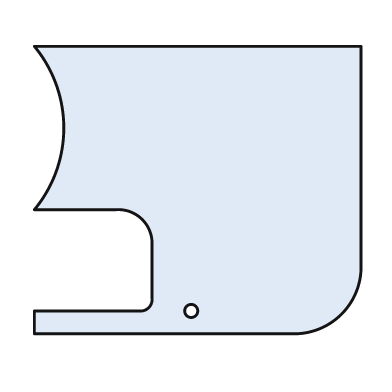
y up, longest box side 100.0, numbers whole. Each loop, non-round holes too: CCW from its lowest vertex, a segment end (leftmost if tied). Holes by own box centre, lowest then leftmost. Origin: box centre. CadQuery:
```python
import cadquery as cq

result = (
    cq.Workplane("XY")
    .moveTo(-50.0, -44.0)
    .lineTo(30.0, -44.0)
    .threePointArc((44.0, -38.0), (50.0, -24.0))
    .lineTo(50.0, 44.0)
    .lineTo(-50.0, 44.0)
    .threePointArc((-41.0, 19.0), (-50.0, -6.0))
    .lineTo(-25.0, -6.0)
    .threePointArc((-17.0, -9.0), (-14.0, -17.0))
    .lineTo(-14.0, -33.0)
    .threePointArc((-15.0, -36.0), (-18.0, -37.0))
    .lineTo(-50.0, -37.0)
    .close()
    .moveTo(-2.0, -37.0)
    .circle(2.0)
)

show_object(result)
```